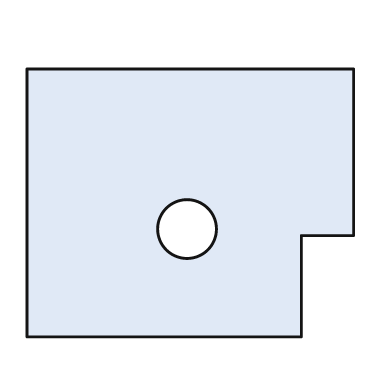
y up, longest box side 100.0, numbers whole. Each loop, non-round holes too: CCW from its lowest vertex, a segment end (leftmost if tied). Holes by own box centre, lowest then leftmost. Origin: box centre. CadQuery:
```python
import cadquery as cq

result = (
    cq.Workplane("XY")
    .moveTo(-50.0, -41.0)
    .lineTo(34.0, -41.0)
    .lineTo(34.0, -10.0)
    .lineTo(50.0, -10.0)
    .lineTo(50.0, 41.0)
    .lineTo(-50.0, 41.0)
    .close()
    .moveTo(-1.0, -8.0)
    .circle(9.0)
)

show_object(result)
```